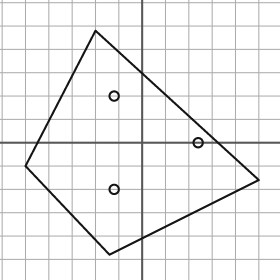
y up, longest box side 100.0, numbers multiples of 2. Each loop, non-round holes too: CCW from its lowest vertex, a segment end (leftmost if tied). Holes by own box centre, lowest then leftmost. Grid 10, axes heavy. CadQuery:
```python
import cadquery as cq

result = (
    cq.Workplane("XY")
    .moveTo(-14.0, -48.0)
    .lineTo(50.0, -16.0)
    .lineTo(-20.0, 48.0)
    .lineTo(-50.0, -10.0)
    .close()
    .moveTo(-12.0, -20.0)
    .circle(2.0)
    .moveTo(24.0, 0.0)
    .circle(2.0)
    .moveTo(-12.0, 20.0)
    .circle(2.0)
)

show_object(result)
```